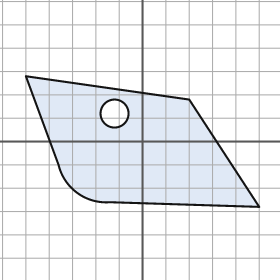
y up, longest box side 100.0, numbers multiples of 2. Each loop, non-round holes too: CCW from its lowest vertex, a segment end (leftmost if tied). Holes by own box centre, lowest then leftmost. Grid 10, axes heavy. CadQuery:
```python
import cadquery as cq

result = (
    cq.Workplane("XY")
    .moveTo(50.0, -28.0)
    .lineTo(20.0, 18.0)
    .lineTo(-50.0, 28.0)
    .lineTo(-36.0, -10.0)
    .threePointArc((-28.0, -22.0), (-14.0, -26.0))
    .close()
    .moveTo(-12.0, 12.0)
    .circle(6.0)
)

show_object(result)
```